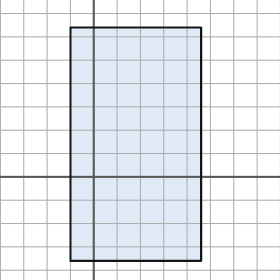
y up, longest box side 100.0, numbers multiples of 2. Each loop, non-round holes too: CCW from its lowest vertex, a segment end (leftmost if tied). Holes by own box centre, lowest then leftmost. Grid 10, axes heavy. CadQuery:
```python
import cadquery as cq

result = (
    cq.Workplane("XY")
    .moveTo(-10.0, -36.0)
    .lineTo(46.0, -36.0)
    .lineTo(46.0, 64.0)
    .lineTo(-10.0, 64.0)
    .close()
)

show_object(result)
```